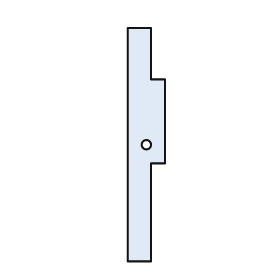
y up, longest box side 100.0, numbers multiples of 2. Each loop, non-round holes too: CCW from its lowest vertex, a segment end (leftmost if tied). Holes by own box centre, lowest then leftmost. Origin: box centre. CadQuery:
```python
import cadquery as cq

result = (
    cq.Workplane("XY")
    .moveTo(-8.0, -50.0)
    .lineTo(2.0, -50.0)
    .lineTo(2.0, -8.0)
    .lineTo(8.0, -8.0)
    .lineTo(8.0, 28.0)
    .lineTo(2.0, 28.0)
    .lineTo(2.0, 50.0)
    .lineTo(-8.0, 50.0)
    .close()
    .moveTo(0.0, 0.0)
    .circle(2.0)
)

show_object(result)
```